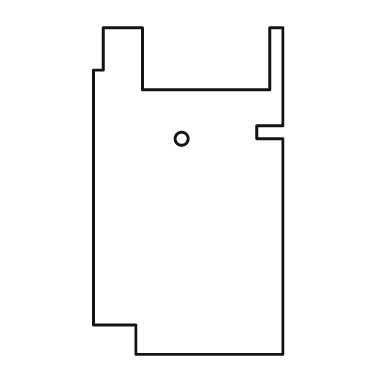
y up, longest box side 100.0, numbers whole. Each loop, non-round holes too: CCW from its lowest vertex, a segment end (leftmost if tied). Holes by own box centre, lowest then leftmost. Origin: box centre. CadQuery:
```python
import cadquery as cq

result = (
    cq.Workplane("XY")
    .moveTo(-16.0, -50.0)
    .lineTo(29.0, -50.0)
    .lineTo(29.0, 16.0)
    .lineTo(21.0, 16.0)
    .lineTo(21.0, 20.0)
    .lineTo(29.0, 20.0)
    .lineTo(29.0, 50.0)
    .lineTo(25.0, 50.0)
    .lineTo(25.0, 31.0)
    .lineTo(-14.0, 31.0)
    .lineTo(-14.0, 50.0)
    .lineTo(-26.0, 50.0)
    .lineTo(-26.0, 37.0)
    .lineTo(-29.0, 37.0)
    .lineTo(-29.0, -41.0)
    .lineTo(-16.0, -41.0)
    .close()
    .moveTo(-2.0, 16.0)
    .circle(2.0)
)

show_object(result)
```